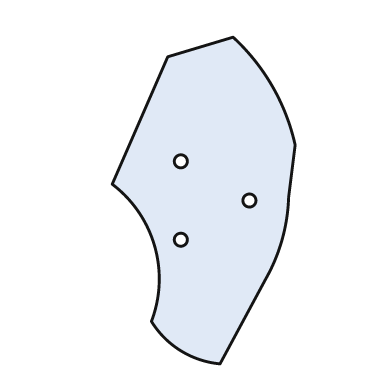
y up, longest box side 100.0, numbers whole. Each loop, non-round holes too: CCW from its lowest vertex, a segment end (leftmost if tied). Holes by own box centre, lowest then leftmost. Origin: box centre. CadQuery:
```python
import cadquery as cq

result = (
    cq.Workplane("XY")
    .moveTo(5.0, -50.0)
    .lineTo(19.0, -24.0)
    .threePointArc((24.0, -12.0), (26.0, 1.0))
    .lineTo(28.0, 17.0)
    .threePointArc((21.0, 35.0), (9.0, 50.0))
    .lineTo(-11.0, 44.0)
    .lineTo(-28.0, 5.0)
    .threePointArc((-15.0, -14.0), (-16.0, -37.0))
    .threePointArc((-7.0, -46.0), (5.0, -50.0))
    .close()
    .moveTo(-7.0, -12.0)
    .circle(2.0)
    .moveTo(14.0, 0.0)
    .circle(2.0)
    .moveTo(-7.0, 12.0)
    .circle(2.0)
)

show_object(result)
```